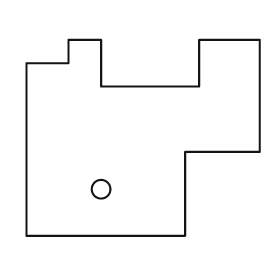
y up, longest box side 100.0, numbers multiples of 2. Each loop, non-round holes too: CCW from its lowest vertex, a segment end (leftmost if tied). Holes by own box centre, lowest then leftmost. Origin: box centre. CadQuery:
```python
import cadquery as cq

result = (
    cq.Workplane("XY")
    .moveTo(-50.0, -42.0)
    .lineTo(18.0, -42.0)
    .lineTo(18.0, -6.0)
    .lineTo(50.0, -6.0)
    .lineTo(50.0, 42.0)
    .lineTo(24.0, 42.0)
    .lineTo(24.0, 22.0)
    .lineTo(-18.0, 22.0)
    .lineTo(-18.0, 42.0)
    .lineTo(-32.0, 42.0)
    .lineTo(-32.0, 32.0)
    .lineTo(-50.0, 32.0)
    .close()
    .moveTo(-18.0, -22.0)
    .circle(4.0)
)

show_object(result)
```